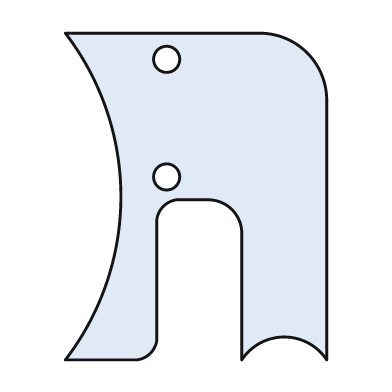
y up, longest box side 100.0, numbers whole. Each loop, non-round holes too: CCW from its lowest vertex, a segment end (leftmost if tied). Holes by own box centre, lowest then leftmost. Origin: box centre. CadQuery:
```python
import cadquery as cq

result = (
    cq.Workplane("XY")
    .moveTo(-40.0, -50.0)
    .lineTo(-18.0, -50.0)
    .threePointArc((-14.0, -48.0), (-12.0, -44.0))
    .lineTo(-12.0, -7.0)
    .threePointArc((-10.0, -3.0), (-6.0, -1.0))
    .lineTo(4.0, -1.0)
    .threePointArc((11.0, -4.0), (14.0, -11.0))
    .lineTo(14.0, -50.0)
    .threePointArc((27.0, -43.0), (40.0, -50.0))
    .lineTo(40.0, 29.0)
    .threePointArc((34.0, 44.0), (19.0, 50.0))
    .lineTo(-40.0, 50.0)
    .threePointArc((-23.0, 0.0), (-40.0, -50.0))
    .close()
    .moveTo(-9.0, 6.0)
    .circle(4.0)
    .moveTo(-9.0, 42.0)
    .circle(4.0)
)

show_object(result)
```